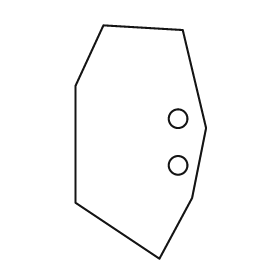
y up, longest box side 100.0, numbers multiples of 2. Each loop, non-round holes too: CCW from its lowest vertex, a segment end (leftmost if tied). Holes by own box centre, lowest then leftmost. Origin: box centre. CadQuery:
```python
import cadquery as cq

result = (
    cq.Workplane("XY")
    .moveTo(8.0, -50.0)
    .lineTo(22.0, -24.0)
    .lineTo(28.0, 6.0)
    .lineTo(18.0, 48.0)
    .lineTo(-16.0, 50.0)
    .lineTo(-28.0, 24.0)
    .lineTo(-28.0, -26.0)
    .close()
    .moveTo(16.0, -10.0)
    .circle(4.0)
    .moveTo(16.0, 10.0)
    .circle(4.0)
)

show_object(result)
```